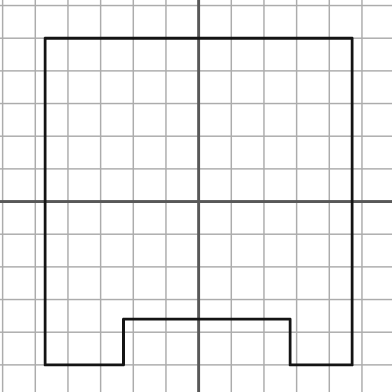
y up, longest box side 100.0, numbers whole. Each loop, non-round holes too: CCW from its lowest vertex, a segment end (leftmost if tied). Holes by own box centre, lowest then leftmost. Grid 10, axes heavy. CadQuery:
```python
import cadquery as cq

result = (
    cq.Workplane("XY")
    .moveTo(-47.0, -50.0)
    .lineTo(-23.0, -50.0)
    .lineTo(-23.0, -36.0)
    .lineTo(28.0, -36.0)
    .lineTo(28.0, -50.0)
    .lineTo(47.0, -50.0)
    .lineTo(47.0, 50.0)
    .lineTo(-47.0, 50.0)
    .close()
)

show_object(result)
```